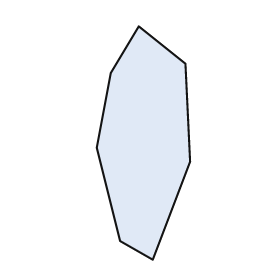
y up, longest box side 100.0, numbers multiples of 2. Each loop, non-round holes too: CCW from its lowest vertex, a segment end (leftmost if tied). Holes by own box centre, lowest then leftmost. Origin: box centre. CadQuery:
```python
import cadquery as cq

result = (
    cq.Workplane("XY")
    .moveTo(4.0, -50.0)
    .lineTo(20.0, -8.0)
    .lineTo(18.0, 34.0)
    .lineTo(-2.0, 50.0)
    .lineTo(-14.0, 30.0)
    .lineTo(-20.0, -2.0)
    .lineTo(-10.0, -42.0)
    .close()
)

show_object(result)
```